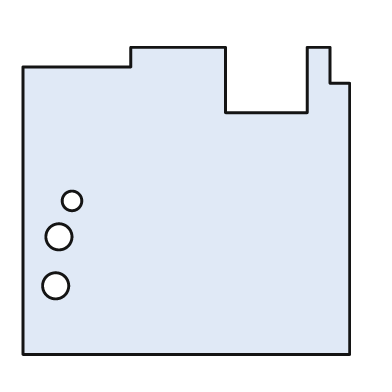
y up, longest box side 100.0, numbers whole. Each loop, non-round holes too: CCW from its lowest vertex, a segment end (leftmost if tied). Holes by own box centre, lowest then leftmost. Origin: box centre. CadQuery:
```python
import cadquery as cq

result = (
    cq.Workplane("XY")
    .moveTo(-50.0, -47.0)
    .lineTo(50.0, -47.0)
    .lineTo(50.0, 36.0)
    .lineTo(44.0, 36.0)
    .lineTo(44.0, 47.0)
    .lineTo(37.0, 47.0)
    .lineTo(37.0, 27.0)
    .lineTo(12.0, 27.0)
    .lineTo(12.0, 47.0)
    .lineTo(-17.0, 47.0)
    .lineTo(-17.0, 41.0)
    .lineTo(-50.0, 41.0)
    .close()
    .moveTo(-40.0, -26.0)
    .circle(4.0)
    .moveTo(-39.0, -11.0)
    .circle(4.0)
    .moveTo(-35.0, 0.0)
    .circle(3.0)
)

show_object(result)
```